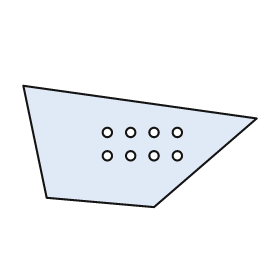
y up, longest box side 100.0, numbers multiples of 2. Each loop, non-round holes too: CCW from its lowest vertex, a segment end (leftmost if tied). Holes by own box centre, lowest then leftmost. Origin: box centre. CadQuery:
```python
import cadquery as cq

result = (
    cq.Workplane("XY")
    .moveTo(6.0, -26.0)
    .lineTo(50.0, 12.0)
    .lineTo(-50.0, 26.0)
    .lineTo(-40.0, -22.0)
    .close()
    .moveTo(-14.0, -4.0)
    .circle(2.0)
    .moveTo(-4.0, -4.0)
    .circle(2.0)
    .moveTo(6.0, -4.0)
    .circle(2.0)
    .moveTo(16.0, -4.0)
    .circle(2.0)
    .moveTo(-14.0, 6.0)
    .circle(2.0)
    .moveTo(-4.0, 6.0)
    .circle(2.0)
    .moveTo(6.0, 6.0)
    .circle(2.0)
    .moveTo(16.0, 6.0)
    .circle(2.0)
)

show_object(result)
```